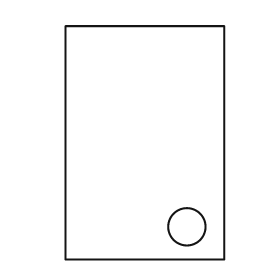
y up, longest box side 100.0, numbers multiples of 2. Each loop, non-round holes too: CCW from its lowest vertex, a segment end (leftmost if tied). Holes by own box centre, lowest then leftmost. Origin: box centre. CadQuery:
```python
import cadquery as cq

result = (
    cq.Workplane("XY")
    .moveTo(-34.0, -50.0)
    .lineTo(34.0, -50.0)
    .lineTo(34.0, 50.0)
    .lineTo(-34.0, 50.0)
    .close()
    .moveTo(18.0, -36.0)
    .circle(8.0)
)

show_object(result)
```